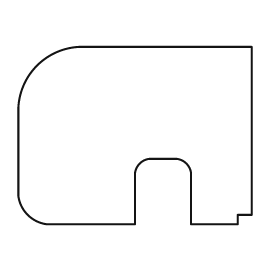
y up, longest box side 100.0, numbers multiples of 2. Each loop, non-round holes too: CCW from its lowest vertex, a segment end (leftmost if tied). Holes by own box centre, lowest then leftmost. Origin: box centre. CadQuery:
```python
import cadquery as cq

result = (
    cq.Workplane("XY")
    .moveTo(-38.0, -38.0)
    .lineTo(0.0, -38.0)
    .lineTo(0.0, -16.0)
    .threePointArc((2.0, -12.0), (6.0, -10.0))
    .lineTo(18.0, -10.0)
    .threePointArc((22.0, -12.0), (24.0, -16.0))
    .lineTo(24.0, -38.0)
    .lineTo(44.0, -38.0)
    .lineTo(44.0, -34.0)
    .lineTo(50.0, -34.0)
    .lineTo(50.0, 38.0)
    .lineTo(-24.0, 38.0)
    .threePointArc((-42.0, 30.0), (-50.0, 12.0))
    .lineTo(-50.0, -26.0)
    .threePointArc((-46.0, -34.0), (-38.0, -38.0))
    .close()
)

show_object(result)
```